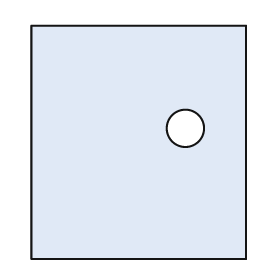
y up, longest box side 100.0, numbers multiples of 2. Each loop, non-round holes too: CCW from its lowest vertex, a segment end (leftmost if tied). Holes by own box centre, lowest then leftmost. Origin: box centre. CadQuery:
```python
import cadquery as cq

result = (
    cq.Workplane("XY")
    .moveTo(-46.0, -50.0)
    .lineTo(46.0, -50.0)
    .lineTo(46.0, 50.0)
    .lineTo(-46.0, 50.0)
    .close()
    .moveTo(20.0, 6.0)
    .circle(8.0)
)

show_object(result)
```